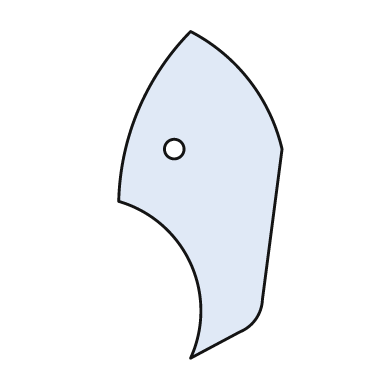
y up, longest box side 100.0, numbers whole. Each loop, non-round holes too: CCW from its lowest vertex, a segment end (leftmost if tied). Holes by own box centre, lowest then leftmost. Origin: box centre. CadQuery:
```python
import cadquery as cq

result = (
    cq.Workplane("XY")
    .moveTo(-3.0, -50.0)
    .lineTo(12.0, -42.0)
    .threePointArc((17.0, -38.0), (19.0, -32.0))
    .lineTo(25.0, 14.0)
    .threePointArc((15.0, 35.0), (-3.0, 50.0))
    .threePointArc((-19.0, 26.0), (-25.0, -2.0))
    .threePointArc((-3.0, -21.0), (-3.0, -50.0))
    .close()
    .moveTo(-8.0, 14.0)
    .circle(3.0)
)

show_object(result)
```